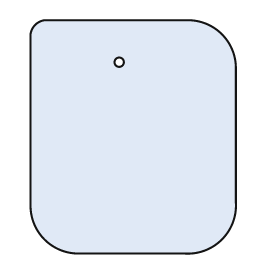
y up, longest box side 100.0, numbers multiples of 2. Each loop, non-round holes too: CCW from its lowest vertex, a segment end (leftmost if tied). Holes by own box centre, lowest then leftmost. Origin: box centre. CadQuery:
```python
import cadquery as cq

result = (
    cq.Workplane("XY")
    .moveTo(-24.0, -50.0)
    .lineTo(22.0, -50.0)
    .threePointArc((38.0, -44.0), (44.0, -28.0))
    .lineTo(44.0, 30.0)
    .threePointArc((38.0, 44.0), (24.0, 50.0))
    .lineTo(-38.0, 50.0)
    .threePointArc((-42.0, 48.0), (-44.0, 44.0))
    .lineTo(-44.0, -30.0)
    .threePointArc((-38.0, -44.0), (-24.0, -50.0))
    .close()
    .moveTo(-6.0, 32.0)
    .circle(2.0)
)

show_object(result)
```